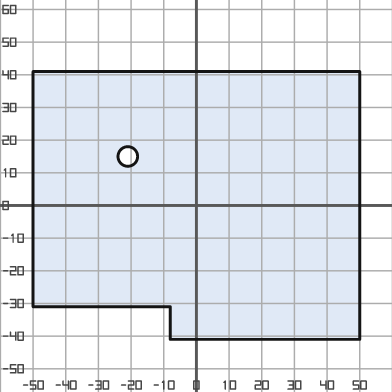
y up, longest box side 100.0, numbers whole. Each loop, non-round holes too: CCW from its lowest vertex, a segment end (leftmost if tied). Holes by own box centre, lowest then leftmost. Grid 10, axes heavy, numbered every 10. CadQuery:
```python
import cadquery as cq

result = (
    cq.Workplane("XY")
    .moveTo(-8.0, -41.0)
    .lineTo(50.0, -41.0)
    .lineTo(50.0, 41.0)
    .lineTo(-50.0, 41.0)
    .lineTo(-50.0, -31.0)
    .lineTo(-8.0, -31.0)
    .close()
    .moveTo(-21.0, 15.0)
    .circle(3.0)
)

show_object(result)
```